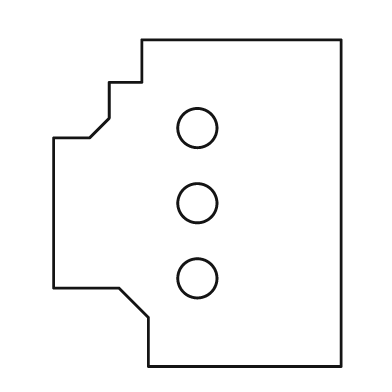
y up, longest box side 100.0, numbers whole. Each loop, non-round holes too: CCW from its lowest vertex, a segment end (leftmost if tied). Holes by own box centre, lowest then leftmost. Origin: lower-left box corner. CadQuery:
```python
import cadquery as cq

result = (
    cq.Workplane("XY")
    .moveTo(29.0, 0.0)
    .lineTo(88.0, 0.0)
    .lineTo(88.0, 100.0)
    .lineTo(27.0, 100.0)
    .lineTo(27.0, 87.0)
    .lineTo(17.0, 87.0)
    .lineTo(17.0, 76.0)
    .lineTo(11.0, 70.0)
    .lineTo(0.0, 70.0)
    .lineTo(0.0, 24.0)
    .lineTo(20.0, 24.0)
    .lineTo(29.0, 15.0)
    .close()
    .moveTo(44.0, 27.0)
    .circle(6.0)
    .moveTo(44.0, 50.0)
    .circle(6.0)
    .moveTo(44.0, 73.0)
    .circle(6.0)
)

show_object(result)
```